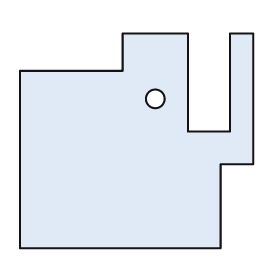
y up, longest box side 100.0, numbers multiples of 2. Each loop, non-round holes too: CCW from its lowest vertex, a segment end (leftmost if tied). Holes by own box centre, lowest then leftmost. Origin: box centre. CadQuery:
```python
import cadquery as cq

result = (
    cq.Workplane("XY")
    .moveTo(-50.0, -46.0)
    .lineTo(36.0, -46.0)
    .lineTo(36.0, -10.0)
    .lineTo(50.0, -10.0)
    .lineTo(50.0, 46.0)
    .lineTo(40.0, 46.0)
    .lineTo(40.0, 4.0)
    .lineTo(22.0, 4.0)
    .lineTo(22.0, 46.0)
    .lineTo(-6.0, 46.0)
    .lineTo(-6.0, 30.0)
    .lineTo(-50.0, 30.0)
    .close()
    .moveTo(8.0, 18.0)
    .circle(4.0)
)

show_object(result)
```